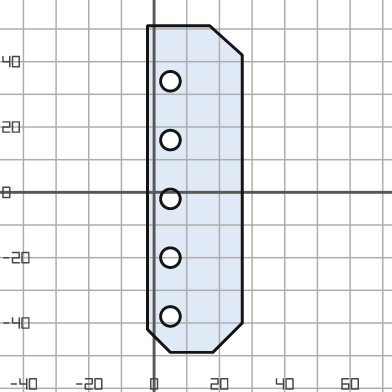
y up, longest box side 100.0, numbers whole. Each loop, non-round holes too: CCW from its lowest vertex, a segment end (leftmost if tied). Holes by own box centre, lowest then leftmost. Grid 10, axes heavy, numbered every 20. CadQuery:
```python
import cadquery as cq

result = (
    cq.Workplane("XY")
    .moveTo(5.0, -49.0)
    .lineTo(18.0, -49.0)
    .lineTo(27.0, -40.0)
    .lineTo(27.0, 42.0)
    .lineTo(17.0, 51.0)
    .lineTo(-2.0, 51.0)
    .lineTo(-2.0, -42.0)
    .close()
    .moveTo(5.0, -38.0)
    .circle(3.0)
    .moveTo(5.0, -20.0)
    .circle(3.0)
    .moveTo(5.0, -2.0)
    .circle(3.0)
    .moveTo(5.0, 16.0)
    .circle(3.0)
    .moveTo(5.0, 34.0)
    .circle(3.0)
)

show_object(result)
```